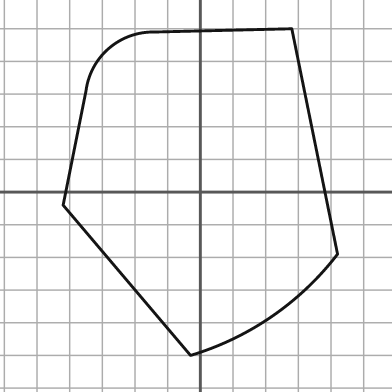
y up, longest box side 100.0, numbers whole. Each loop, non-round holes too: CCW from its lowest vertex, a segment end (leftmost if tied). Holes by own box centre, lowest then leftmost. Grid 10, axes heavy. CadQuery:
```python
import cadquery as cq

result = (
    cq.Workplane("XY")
    .moveTo(-3.0, -50.0)
    .threePointArc((22.0, -38.0), (42.0, -19.0))
    .lineTo(28.0, 50.0)
    .lineTo(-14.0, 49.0)
    .threePointArc((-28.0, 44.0), (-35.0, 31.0))
    .lineTo(-42.0, -4.0)
    .close()
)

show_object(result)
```